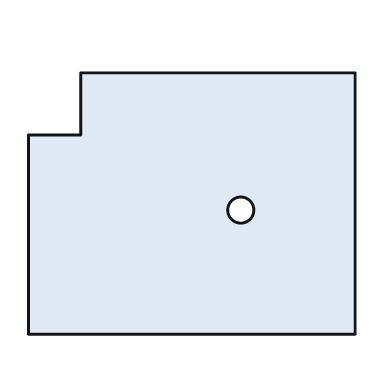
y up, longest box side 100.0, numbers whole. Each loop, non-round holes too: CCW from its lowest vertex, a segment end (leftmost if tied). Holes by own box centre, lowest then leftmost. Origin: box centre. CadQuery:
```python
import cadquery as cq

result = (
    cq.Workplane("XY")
    .moveTo(-50.0, -40.0)
    .lineTo(50.0, -40.0)
    .lineTo(50.0, 40.0)
    .lineTo(-34.0, 40.0)
    .lineTo(-34.0, 21.0)
    .lineTo(-50.0, 21.0)
    .close()
    .moveTo(15.0, -2.0)
    .circle(4.0)
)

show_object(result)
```